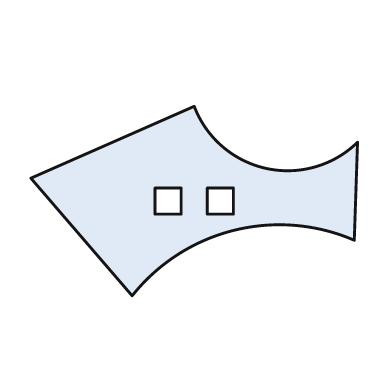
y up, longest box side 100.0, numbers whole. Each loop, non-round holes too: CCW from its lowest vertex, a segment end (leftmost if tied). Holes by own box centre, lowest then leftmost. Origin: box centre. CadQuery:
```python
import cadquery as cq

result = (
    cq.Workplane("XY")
    .moveTo(-19.0, -29.0)
    .threePointArc((12.0, -9.0), (49.0, -12.0))
    .lineTo(50.0, 18.0)
    .threePointArc((22.0, 10.0), (0.0, 29.0))
    .lineTo(-50.0, 7.0)
    .close()
    .moveTo(-12.0, -4.0)
    .lineTo(-4.0, -4.0)
    .lineTo(-4.0, 4.0)
    .lineTo(-12.0, 4.0)
    .close()
    .moveTo(4.0, -4.0)
    .lineTo(12.0, -4.0)
    .lineTo(12.0, 4.0)
    .lineTo(4.0, 4.0)
    .close()
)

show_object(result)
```